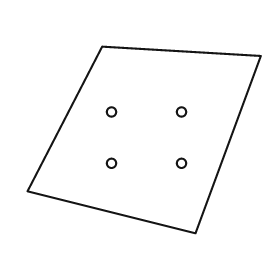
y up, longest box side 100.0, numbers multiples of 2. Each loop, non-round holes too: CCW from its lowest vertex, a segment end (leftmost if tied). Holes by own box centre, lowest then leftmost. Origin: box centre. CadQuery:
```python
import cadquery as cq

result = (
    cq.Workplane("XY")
    .moveTo(22.0, -40.0)
    .lineTo(50.0, 36.0)
    .lineTo(-18.0, 40.0)
    .lineTo(-50.0, -22.0)
    .close()
    .moveTo(-14.0, -10.0)
    .circle(2.0)
    .moveTo(16.0, -10.0)
    .circle(2.0)
    .moveTo(-14.0, 12.0)
    .circle(2.0)
    .moveTo(16.0, 12.0)
    .circle(2.0)
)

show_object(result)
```